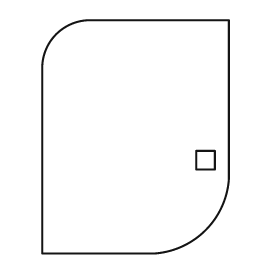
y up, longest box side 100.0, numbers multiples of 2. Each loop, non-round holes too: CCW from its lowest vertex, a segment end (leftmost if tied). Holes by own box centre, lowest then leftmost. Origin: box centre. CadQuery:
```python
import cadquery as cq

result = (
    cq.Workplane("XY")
    .moveTo(-40.0, -50.0)
    .lineTo(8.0, -50.0)
    .threePointArc((30.0, -40.0), (40.0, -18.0))
    .lineTo(40.0, 50.0)
    .lineTo(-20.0, 50.0)
    .threePointArc((-34.0, 44.0), (-40.0, 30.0))
    .close()
    .moveTo(26.0, -14.0)
    .lineTo(34.0, -14.0)
    .lineTo(34.0, -6.0)
    .lineTo(26.0, -6.0)
    .close()
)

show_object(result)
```